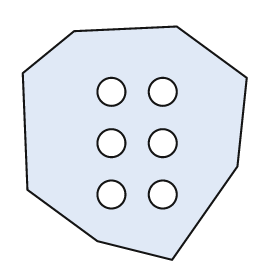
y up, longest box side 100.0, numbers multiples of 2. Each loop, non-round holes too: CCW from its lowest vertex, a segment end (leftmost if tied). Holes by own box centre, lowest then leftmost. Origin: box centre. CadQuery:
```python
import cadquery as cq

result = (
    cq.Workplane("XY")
    .moveTo(16.0, -50.0)
    .lineTo(44.0, -10.0)
    .lineTo(48.0, 28.0)
    .lineTo(18.0, 50.0)
    .lineTo(-26.0, 48.0)
    .lineTo(-48.0, 30.0)
    .lineTo(-46.0, -20.0)
    .lineTo(-16.0, -42.0)
    .close()
    .moveTo(-10.0, -22.0)
    .circle(6.0)
    .moveTo(12.0, -22.0)
    .circle(6.0)
    .moveTo(-10.0, 0.0)
    .circle(6.0)
    .moveTo(12.0, 0.0)
    .circle(6.0)
    .moveTo(-10.0, 22.0)
    .circle(6.0)
    .moveTo(12.0, 22.0)
    .circle(6.0)
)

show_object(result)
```